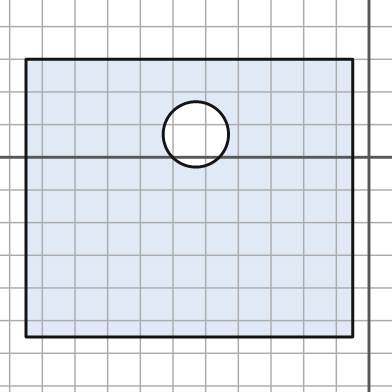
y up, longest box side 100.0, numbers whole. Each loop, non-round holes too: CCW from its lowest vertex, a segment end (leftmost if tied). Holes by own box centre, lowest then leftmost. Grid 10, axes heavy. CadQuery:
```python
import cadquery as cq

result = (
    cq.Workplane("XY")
    .moveTo(-105.0, -55.0)
    .lineTo(-5.0, -55.0)
    .lineTo(-5.0, 30.0)
    .lineTo(-105.0, 30.0)
    .close()
    .moveTo(-53.0, 7.0)
    .circle(10.0)
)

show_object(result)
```